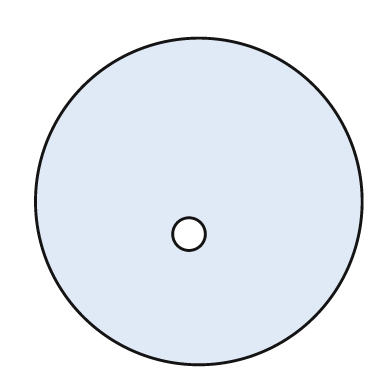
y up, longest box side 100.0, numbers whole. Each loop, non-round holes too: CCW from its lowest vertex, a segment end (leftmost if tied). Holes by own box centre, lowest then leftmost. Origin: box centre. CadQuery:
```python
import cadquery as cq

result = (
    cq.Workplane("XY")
    .moveTo(0.0, 0.0)
    .circle(50.0)
    .moveTo(-3.0, -10.0)
    .circle(5.0)
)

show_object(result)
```